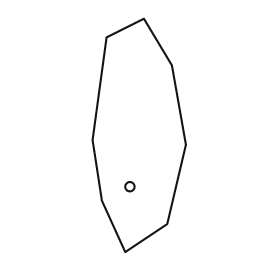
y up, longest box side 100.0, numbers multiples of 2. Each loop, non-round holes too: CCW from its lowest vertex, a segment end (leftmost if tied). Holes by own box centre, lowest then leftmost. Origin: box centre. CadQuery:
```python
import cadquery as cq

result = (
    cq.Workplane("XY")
    .moveTo(-6.0, -50.0)
    .lineTo(12.0, -38.0)
    .lineTo(20.0, -4.0)
    .lineTo(14.0, 30.0)
    .lineTo(2.0, 50.0)
    .lineTo(-14.0, 42.0)
    .lineTo(-20.0, -2.0)
    .lineTo(-16.0, -28.0)
    .close()
    .moveTo(-4.0, -22.0)
    .circle(2.0)
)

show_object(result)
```